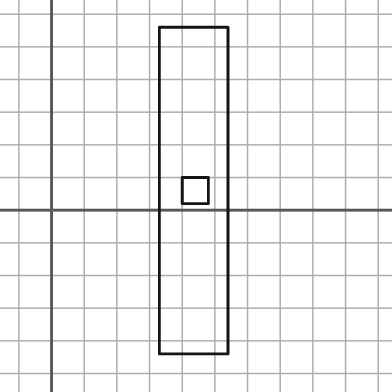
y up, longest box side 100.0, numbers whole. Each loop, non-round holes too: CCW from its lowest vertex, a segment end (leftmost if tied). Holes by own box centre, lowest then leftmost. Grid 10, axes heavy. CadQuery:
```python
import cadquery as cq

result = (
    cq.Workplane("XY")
    .moveTo(33.0, -44.0)
    .lineTo(54.0, -44.0)
    .lineTo(54.0, 56.0)
    .lineTo(33.0, 56.0)
    .close()
    .moveTo(40.0, 2.0)
    .lineTo(48.0, 2.0)
    .lineTo(48.0, 10.0)
    .lineTo(40.0, 10.0)
    .close()
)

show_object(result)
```